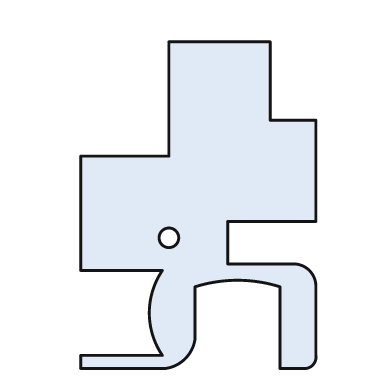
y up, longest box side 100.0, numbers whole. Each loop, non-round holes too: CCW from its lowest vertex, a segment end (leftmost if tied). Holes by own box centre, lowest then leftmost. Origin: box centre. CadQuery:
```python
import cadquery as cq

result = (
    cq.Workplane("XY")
    .moveTo(-36.0, -50.0)
    .lineTo(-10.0, -50.0)
    .threePointArc((-4.0, -47.0), (-1.0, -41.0))
    .lineTo(-1.0, -25.0)
    .threePointArc((12.0, -23.0), (25.0, -25.0))
    .lineTo(25.0, -50.0)
    .lineTo(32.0, -50.0)
    .threePointArc((35.0, -49.0), (36.0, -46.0))
    .lineTo(36.0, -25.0)
    .threePointArc((34.0, -20.0), (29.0, -18.0))
    .lineTo(9.0, -18.0)
    .lineTo(9.0, -5.0)
    .lineTo(36.0, -5.0)
    .lineTo(36.0, 26.0)
    .lineTo(22.0, 26.0)
    .lineTo(22.0, 50.0)
    .lineTo(-9.0, 50.0)
    .lineTo(-9.0, 15.0)
    .lineTo(-36.0, 15.0)
    .lineTo(-36.0, -20.0)
    .lineTo(-11.0, -20.0)
    .threePointArc((-15.0, -33.0), (-11.0, -46.0))
    .lineTo(-36.0, -46.0)
    .close()
    .moveTo(-9.0, -10.0)
    .circle(3.0)
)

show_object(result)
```